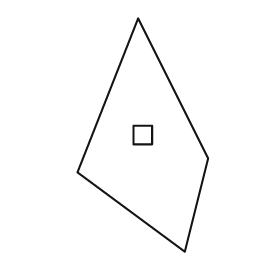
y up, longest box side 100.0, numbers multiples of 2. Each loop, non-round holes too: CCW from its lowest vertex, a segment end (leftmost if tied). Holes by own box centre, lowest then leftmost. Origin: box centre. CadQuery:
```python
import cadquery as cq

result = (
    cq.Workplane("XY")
    .moveTo(18.0, -50.0)
    .lineTo(28.0, -10.0)
    .lineTo(-2.0, 50.0)
    .lineTo(-28.0, -16.0)
    .close()
    .moveTo(-4.0, -4.0)
    .lineTo(4.0, -4.0)
    .lineTo(4.0, 4.0)
    .lineTo(-4.0, 4.0)
    .close()
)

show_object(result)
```